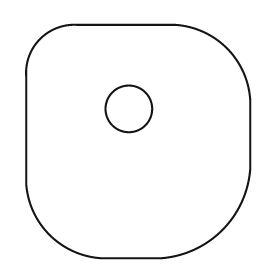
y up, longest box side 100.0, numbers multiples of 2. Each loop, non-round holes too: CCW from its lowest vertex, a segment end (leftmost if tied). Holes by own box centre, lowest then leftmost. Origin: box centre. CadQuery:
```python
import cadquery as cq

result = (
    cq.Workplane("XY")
    .moveTo(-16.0, -50.0)
    .lineTo(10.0, -50.0)
    .threePointArc((36.0, -38.0), (48.0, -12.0))
    .lineTo(48.0, 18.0)
    .threePointArc((38.0, 40.0), (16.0, 50.0))
    .lineTo(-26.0, 50.0)
    .threePointArc((-42.0, 44.0), (-48.0, 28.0))
    .lineTo(-48.0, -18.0)
    .threePointArc((-38.0, -40.0), (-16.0, -50.0))
    .close()
    .moveTo(-4.0, 14.0)
    .circle(10.0)
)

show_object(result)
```